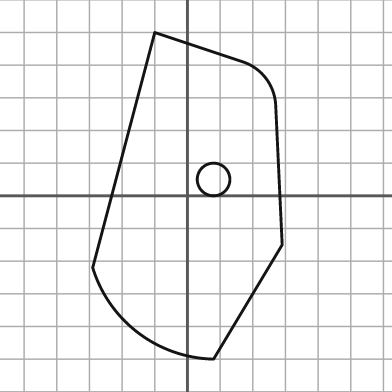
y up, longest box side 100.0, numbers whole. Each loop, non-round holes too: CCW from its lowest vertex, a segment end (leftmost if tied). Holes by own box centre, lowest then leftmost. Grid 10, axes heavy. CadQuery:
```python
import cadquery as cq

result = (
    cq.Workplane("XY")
    .moveTo(8.0, -50.0)
    .lineTo(29.0, -15.0)
    .lineTo(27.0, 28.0)
    .threePointArc((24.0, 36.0), (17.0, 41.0))
    .lineTo(-10.0, 50.0)
    .lineTo(-29.0, -22.0)
    .threePointArc((-15.0, -42.0), (8.0, -50.0))
    .close()
    .moveTo(8.0, 5.0)
    .circle(5.0)
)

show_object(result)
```